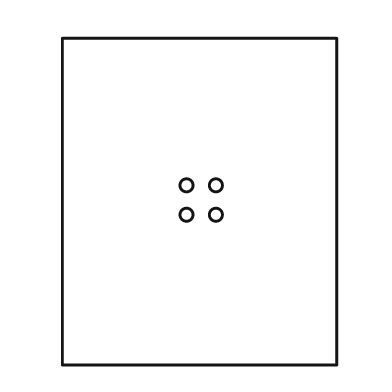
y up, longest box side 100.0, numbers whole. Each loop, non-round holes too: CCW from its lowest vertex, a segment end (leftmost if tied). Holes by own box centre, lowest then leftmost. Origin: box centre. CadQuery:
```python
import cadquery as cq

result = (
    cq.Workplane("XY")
    .moveTo(-42.0, -50.0)
    .lineTo(42.0, -50.0)
    .lineTo(42.0, 50.0)
    .lineTo(-42.0, 50.0)
    .close()
    .moveTo(-4.0, -4.0)
    .circle(2.0)
    .moveTo(5.0, -4.0)
    .circle(2.0)
    .moveTo(-4.0, 5.0)
    .circle(2.0)
    .moveTo(5.0, 5.0)
    .circle(2.0)
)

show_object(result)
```